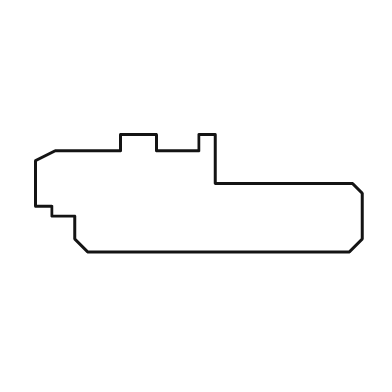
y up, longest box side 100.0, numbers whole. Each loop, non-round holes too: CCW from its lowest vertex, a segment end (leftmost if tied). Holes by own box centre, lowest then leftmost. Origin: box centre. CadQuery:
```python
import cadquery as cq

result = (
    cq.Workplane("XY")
    .moveTo(-34.0, -18.0)
    .lineTo(46.0, -18.0)
    .lineTo(50.0, -14.0)
    .lineTo(50.0, 0.0)
    .lineTo(47.0, 3.0)
    .lineTo(5.0, 3.0)
    .lineTo(5.0, 18.0)
    .lineTo(0.0, 18.0)
    .lineTo(0.0, 13.0)
    .lineTo(-13.0, 13.0)
    .lineTo(-13.0, 18.0)
    .lineTo(-24.0, 18.0)
    .lineTo(-24.0, 13.0)
    .lineTo(-44.0, 13.0)
    .lineTo(-50.0, 10.0)
    .lineTo(-50.0, -4.0)
    .lineTo(-45.0, -4.0)
    .lineTo(-45.0, -7.0)
    .lineTo(-38.0, -7.0)
    .lineTo(-38.0, -14.0)
    .close()
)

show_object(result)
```